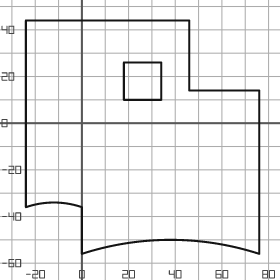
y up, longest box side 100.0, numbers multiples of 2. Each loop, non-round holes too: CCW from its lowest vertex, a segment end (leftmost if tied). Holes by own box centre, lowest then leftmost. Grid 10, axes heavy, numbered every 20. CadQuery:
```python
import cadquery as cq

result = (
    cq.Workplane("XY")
    .moveTo(0.0, -56.0)
    .threePointArc((38.0, -50.0), (76.0, -56.0))
    .lineTo(76.0, 14.0)
    .lineTo(46.0, 14.0)
    .lineTo(46.0, 44.0)
    .lineTo(-24.0, 44.0)
    .lineTo(-24.0, -36.0)
    .threePointArc((-12.0, -34.0), (0.0, -36.0))
    .close()
    .moveTo(18.0, 10.0)
    .lineTo(34.0, 10.0)
    .lineTo(34.0, 26.0)
    .lineTo(18.0, 26.0)
    .close()
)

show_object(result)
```